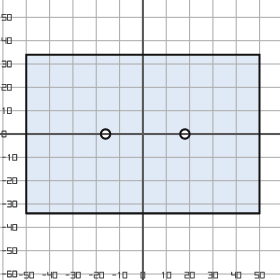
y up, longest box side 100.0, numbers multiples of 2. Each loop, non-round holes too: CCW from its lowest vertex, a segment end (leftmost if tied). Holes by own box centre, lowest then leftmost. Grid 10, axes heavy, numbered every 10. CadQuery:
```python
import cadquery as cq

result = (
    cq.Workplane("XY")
    .moveTo(-50.0, -34.0)
    .lineTo(50.0, -34.0)
    .lineTo(50.0, 34.0)
    .lineTo(-50.0, 34.0)
    .close()
    .moveTo(-16.0, 0.0)
    .circle(2.0)
    .moveTo(18.0, 0.0)
    .circle(2.0)
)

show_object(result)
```